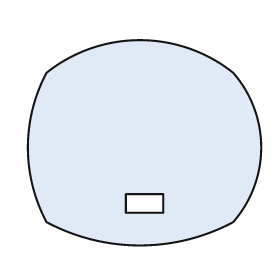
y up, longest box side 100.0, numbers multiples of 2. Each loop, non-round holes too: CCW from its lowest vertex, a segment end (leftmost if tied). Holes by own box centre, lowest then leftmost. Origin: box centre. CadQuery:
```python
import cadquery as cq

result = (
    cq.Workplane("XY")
    .moveTo(-42.0, -34.0)
    .threePointArc((-2.0, -44.0), (38.0, -34.0))
    .threePointArc((50.0, -2.0), (38.0, 30.0))
    .threePointArc((-2.0, 44.0), (-42.0, 30.0))
    .threePointArc((-50.0, -2.0), (-42.0, -34.0))
    .close()
    .moveTo(-8.0, -30.0)
    .lineTo(8.0, -30.0)
    .lineTo(8.0, -22.0)
    .lineTo(-8.0, -22.0)
    .close()
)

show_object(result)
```